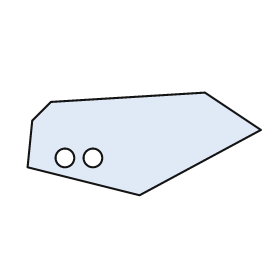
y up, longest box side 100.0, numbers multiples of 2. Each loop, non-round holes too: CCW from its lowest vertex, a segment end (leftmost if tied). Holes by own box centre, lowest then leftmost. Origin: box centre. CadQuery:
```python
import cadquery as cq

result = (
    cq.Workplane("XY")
    .moveTo(-2.0, -22.0)
    .lineTo(50.0, 6.0)
    .lineTo(26.0, 22.0)
    .lineTo(-40.0, 18.0)
    .lineTo(-48.0, 10.0)
    .lineTo(-50.0, -10.0)
    .close()
    .moveTo(-34.0, -6.0)
    .circle(4.0)
    .moveTo(-22.0, -6.0)
    .circle(4.0)
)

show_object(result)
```